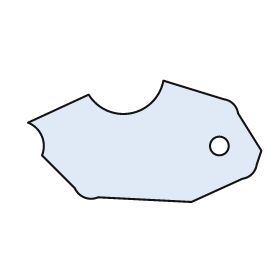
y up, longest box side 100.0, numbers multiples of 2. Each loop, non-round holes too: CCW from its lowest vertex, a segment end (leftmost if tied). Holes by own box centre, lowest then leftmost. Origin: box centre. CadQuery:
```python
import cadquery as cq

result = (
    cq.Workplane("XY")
    .moveTo(20.0, -26.0)
    .lineTo(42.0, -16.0)
    .threePointArc((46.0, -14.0), (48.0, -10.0))
    .lineTo(50.0, -4.0)
    .lineTo(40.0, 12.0)
    .threePointArc((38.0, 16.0), (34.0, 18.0))
    .lineTo(8.0, 26.0)
    .threePointArc((-6.0, 12.0), (-24.0, 20.0))
    .lineTo(-50.0, 8.0)
    .threePointArc((-44.0, 2.0), (-44.0, -6.0))
    .lineTo(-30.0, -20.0)
    .threePointArc((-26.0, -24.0), (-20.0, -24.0))
    .close()
    .moveTo(32.0, -2.0)
    .circle(4.0)
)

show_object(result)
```